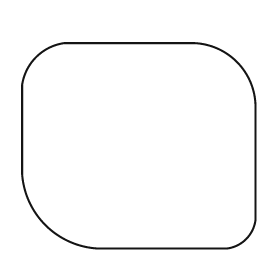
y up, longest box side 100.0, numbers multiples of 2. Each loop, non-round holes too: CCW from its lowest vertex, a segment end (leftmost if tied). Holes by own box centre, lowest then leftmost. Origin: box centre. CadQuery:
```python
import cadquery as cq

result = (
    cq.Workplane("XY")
    .moveTo(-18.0, -44.0)
    .lineTo(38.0, -44.0)
    .threePointArc((46.0, -40.0), (50.0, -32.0))
    .lineTo(50.0, 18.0)
    .threePointArc((42.0, 36.0), (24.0, 44.0))
    .lineTo(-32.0, 44.0)
    .threePointArc((-44.0, 38.0), (-50.0, 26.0))
    .lineTo(-50.0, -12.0)
    .threePointArc((-40.0, -34.0), (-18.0, -44.0))
    .close()
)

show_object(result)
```